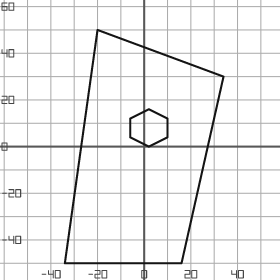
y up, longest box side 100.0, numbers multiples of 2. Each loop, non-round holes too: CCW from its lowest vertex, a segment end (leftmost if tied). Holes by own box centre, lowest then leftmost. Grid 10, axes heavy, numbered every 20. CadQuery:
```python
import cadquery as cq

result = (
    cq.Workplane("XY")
    .moveTo(-34.0, -50.0)
    .lineTo(16.0, -50.0)
    .lineTo(34.0, 30.0)
    .lineTo(-20.0, 50.0)
    .close()
    .moveTo(2.0, 0.0)
    .lineTo(10.0, 4.0)
    .lineTo(10.0, 12.0)
    .lineTo(2.0, 16.0)
    .lineTo(-6.0, 12.0)
    .lineTo(-6.0, 4.0)
    .close()
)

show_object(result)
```